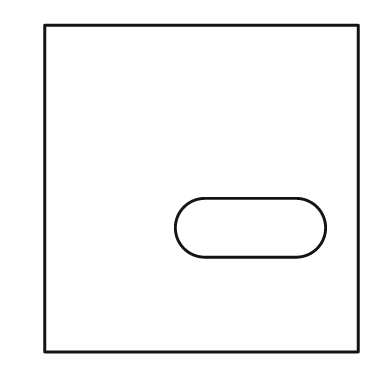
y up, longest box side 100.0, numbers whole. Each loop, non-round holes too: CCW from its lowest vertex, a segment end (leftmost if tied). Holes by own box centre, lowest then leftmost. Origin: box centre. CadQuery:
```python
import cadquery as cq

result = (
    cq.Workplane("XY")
    .moveTo(-48.0, -50.0)
    .lineTo(48.0, -50.0)
    .lineTo(48.0, 50.0)
    .lineTo(-48.0, 50.0)
    .close()
    .moveTo(1.0, -21.0)
    .lineTo(29.0, -21.0)
    .threePointArc((38.0, -12.0), (29.0, -3.0))
    .lineTo(1.0, -3.0)
    .threePointArc((-8.0, -12.0), (1.0, -21.0))
    .close()
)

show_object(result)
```